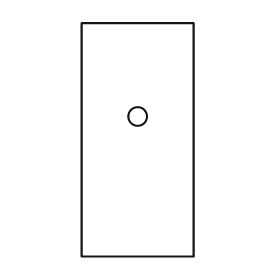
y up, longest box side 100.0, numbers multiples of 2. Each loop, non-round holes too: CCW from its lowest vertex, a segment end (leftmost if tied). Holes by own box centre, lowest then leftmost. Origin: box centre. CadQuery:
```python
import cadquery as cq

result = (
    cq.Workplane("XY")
    .moveTo(-24.0, -50.0)
    .lineTo(24.0, -50.0)
    .lineTo(24.0, 50.0)
    .lineTo(-24.0, 50.0)
    .close()
    .moveTo(0.0, 10.0)
    .circle(4.0)
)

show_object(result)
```